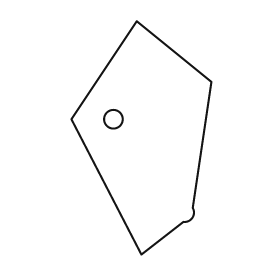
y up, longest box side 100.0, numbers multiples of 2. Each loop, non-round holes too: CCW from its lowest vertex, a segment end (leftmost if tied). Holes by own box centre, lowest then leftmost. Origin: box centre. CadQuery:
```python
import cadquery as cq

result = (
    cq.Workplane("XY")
    .moveTo(0.0, -50.0)
    .lineTo(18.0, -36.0)
    .threePointArc((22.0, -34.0), (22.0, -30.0))
    .lineTo(30.0, 24.0)
    .lineTo(-2.0, 50.0)
    .lineTo(-30.0, 8.0)
    .close()
    .moveTo(-12.0, 8.0)
    .circle(4.0)
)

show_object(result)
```